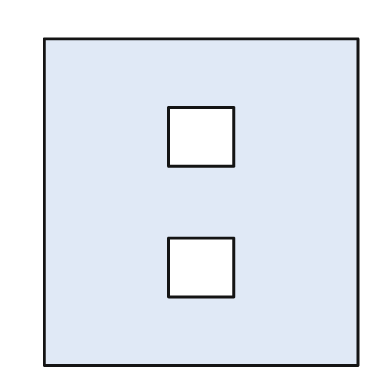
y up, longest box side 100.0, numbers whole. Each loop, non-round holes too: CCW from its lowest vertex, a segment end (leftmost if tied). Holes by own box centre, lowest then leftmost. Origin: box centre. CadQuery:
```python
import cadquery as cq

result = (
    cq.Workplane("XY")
    .moveTo(-48.0, -50.0)
    .lineTo(48.0, -50.0)
    .lineTo(48.0, 50.0)
    .lineTo(-48.0, 50.0)
    .close()
    .moveTo(-10.0, -29.0)
    .lineTo(10.0, -29.0)
    .lineTo(10.0, -11.0)
    .lineTo(-10.0, -11.0)
    .close()
    .moveTo(-10.0, 11.0)
    .lineTo(10.0, 11.0)
    .lineTo(10.0, 29.0)
    .lineTo(-10.0, 29.0)
    .close()
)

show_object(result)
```